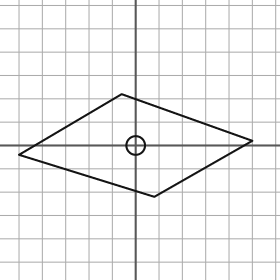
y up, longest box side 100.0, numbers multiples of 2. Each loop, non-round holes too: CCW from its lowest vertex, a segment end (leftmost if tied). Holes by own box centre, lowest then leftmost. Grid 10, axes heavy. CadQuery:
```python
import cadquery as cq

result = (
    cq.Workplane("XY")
    .moveTo(8.0, -22.0)
    .lineTo(50.0, 2.0)
    .lineTo(-6.0, 22.0)
    .lineTo(-50.0, -4.0)
    .close()
    .moveTo(0.0, 0.0)
    .circle(4.0)
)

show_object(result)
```